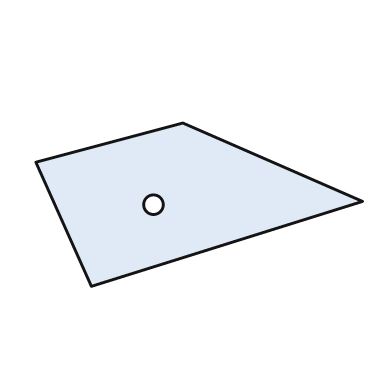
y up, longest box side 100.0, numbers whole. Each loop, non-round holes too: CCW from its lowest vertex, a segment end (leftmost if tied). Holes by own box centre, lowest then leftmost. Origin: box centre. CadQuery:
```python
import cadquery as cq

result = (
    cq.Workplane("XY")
    .moveTo(-33.0, -25.0)
    .lineTo(50.0, 1.0)
    .lineTo(-5.0, 25.0)
    .lineTo(-50.0, 13.0)
    .close()
    .moveTo(-14.0, 0.0)
    .circle(3.0)
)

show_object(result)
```